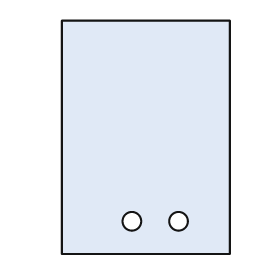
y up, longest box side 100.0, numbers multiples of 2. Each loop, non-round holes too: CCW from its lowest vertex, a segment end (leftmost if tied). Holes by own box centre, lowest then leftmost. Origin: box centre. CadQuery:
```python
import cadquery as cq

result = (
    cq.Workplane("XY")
    .moveTo(-36.0, -50.0)
    .lineTo(36.0, -50.0)
    .lineTo(36.0, 50.0)
    .lineTo(-36.0, 50.0)
    .close()
    .moveTo(-6.0, -36.0)
    .circle(4.0)
    .moveTo(14.0, -36.0)
    .circle(4.0)
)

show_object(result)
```